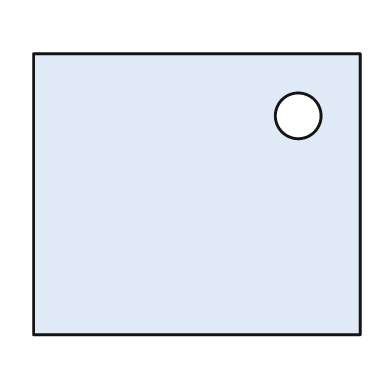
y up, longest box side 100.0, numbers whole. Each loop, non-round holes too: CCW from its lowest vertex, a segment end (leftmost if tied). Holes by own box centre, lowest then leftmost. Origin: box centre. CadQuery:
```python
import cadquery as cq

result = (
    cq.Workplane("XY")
    .moveTo(-50.0, -43.0)
    .lineTo(50.0, -43.0)
    .lineTo(50.0, 43.0)
    .lineTo(-50.0, 43.0)
    .close()
    .moveTo(31.0, 24.0)
    .circle(7.0)
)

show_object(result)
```